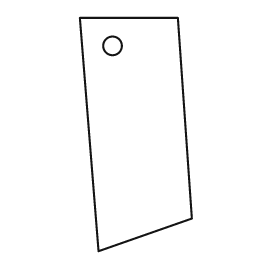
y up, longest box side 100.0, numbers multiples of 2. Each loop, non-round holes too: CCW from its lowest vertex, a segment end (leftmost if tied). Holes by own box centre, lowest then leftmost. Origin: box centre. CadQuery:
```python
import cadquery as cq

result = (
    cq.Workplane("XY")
    .moveTo(-16.0, -50.0)
    .lineTo(24.0, -36.0)
    .lineTo(18.0, 50.0)
    .lineTo(-24.0, 50.0)
    .close()
    .moveTo(-10.0, 38.0)
    .circle(4.0)
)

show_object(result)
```